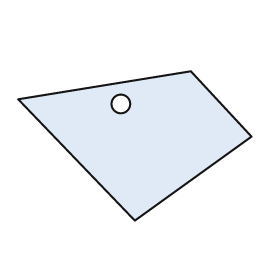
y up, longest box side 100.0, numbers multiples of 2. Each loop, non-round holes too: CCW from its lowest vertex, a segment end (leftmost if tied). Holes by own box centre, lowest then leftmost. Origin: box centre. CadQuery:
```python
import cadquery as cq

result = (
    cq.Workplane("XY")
    .moveTo(0.0, -32.0)
    .lineTo(50.0, 4.0)
    .lineTo(24.0, 32.0)
    .lineTo(-50.0, 20.0)
    .close()
    .moveTo(-6.0, 18.0)
    .circle(4.0)
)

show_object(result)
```